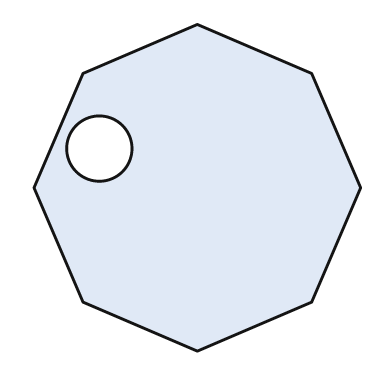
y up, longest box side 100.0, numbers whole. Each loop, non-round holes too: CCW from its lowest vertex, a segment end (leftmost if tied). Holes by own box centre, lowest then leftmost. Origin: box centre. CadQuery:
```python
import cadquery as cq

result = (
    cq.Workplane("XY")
    .moveTo(0.0, -50.0)
    .lineTo(35.0, -35.0)
    .lineTo(50.0, 0.0)
    .lineTo(35.0, 35.0)
    .lineTo(0.0, 50.0)
    .lineTo(-35.0, 35.0)
    .lineTo(-50.0, 0.0)
    .lineTo(-35.0, -35.0)
    .close()
    .moveTo(-30.0, 12.0)
    .circle(10.0)
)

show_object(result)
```